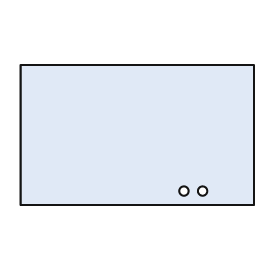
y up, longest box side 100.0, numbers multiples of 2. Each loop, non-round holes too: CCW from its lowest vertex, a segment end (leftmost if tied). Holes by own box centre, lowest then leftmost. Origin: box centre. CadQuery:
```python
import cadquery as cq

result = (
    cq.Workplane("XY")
    .moveTo(-50.0, -30.0)
    .lineTo(50.0, -30.0)
    .lineTo(50.0, 30.0)
    .lineTo(-50.0, 30.0)
    .close()
    .moveTo(20.0, -24.0)
    .circle(2.0)
    .moveTo(28.0, -24.0)
    .circle(2.0)
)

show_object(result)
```